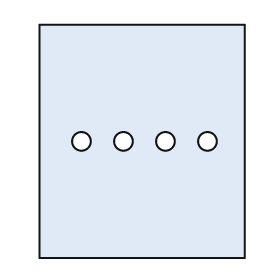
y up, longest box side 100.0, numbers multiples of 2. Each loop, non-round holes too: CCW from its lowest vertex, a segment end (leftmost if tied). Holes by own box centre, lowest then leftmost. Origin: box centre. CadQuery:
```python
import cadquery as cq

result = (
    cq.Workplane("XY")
    .moveTo(-44.0, -50.0)
    .lineTo(44.0, -50.0)
    .lineTo(44.0, 50.0)
    .lineTo(-44.0, 50.0)
    .close()
    .moveTo(-26.0, 0.0)
    .circle(4.0)
    .moveTo(-8.0, 0.0)
    .circle(4.0)
    .moveTo(10.0, 0.0)
    .circle(4.0)
    .moveTo(28.0, 0.0)
    .circle(4.0)
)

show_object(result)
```